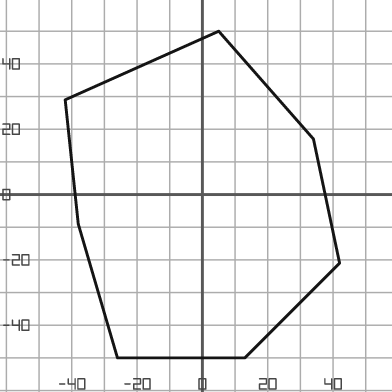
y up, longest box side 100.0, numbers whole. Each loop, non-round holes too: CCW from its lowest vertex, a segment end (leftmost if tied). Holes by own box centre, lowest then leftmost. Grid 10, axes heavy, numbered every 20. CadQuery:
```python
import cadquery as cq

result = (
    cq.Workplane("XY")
    .moveTo(-26.0, -50.0)
    .lineTo(13.0, -50.0)
    .lineTo(42.0, -21.0)
    .lineTo(34.0, 17.0)
    .lineTo(5.0, 50.0)
    .lineTo(-42.0, 29.0)
    .lineTo(-38.0, -9.0)
    .close()
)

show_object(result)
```